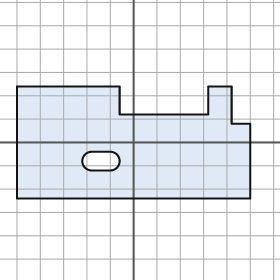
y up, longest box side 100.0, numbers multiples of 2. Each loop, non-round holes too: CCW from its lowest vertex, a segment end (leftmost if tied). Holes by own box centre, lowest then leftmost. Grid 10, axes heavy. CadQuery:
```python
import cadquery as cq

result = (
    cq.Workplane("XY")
    .moveTo(-50.0, -24.0)
    .lineTo(50.0, -24.0)
    .lineTo(50.0, 8.0)
    .lineTo(42.0, 8.0)
    .lineTo(42.0, 24.0)
    .lineTo(32.0, 24.0)
    .lineTo(32.0, 12.0)
    .lineTo(-6.0, 12.0)
    .lineTo(-6.0, 24.0)
    .lineTo(-50.0, 24.0)
    .close()
    .moveTo(-18.0, -12.0)
    .lineTo(-10.0, -12.0)
    .threePointArc((-6.0, -8.0), (-10.0, -4.0))
    .lineTo(-18.0, -4.0)
    .threePointArc((-22.0, -8.0), (-18.0, -12.0))
    .close()
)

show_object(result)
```